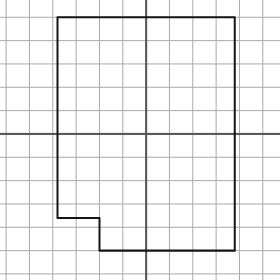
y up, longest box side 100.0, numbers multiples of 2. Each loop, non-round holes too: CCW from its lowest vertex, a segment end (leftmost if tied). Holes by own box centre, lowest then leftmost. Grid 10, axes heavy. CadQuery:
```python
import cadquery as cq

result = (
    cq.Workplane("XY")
    .moveTo(-20.0, -50.0)
    .lineTo(38.0, -50.0)
    .lineTo(38.0, 50.0)
    .lineTo(-38.0, 50.0)
    .lineTo(-38.0, -36.0)
    .lineTo(-20.0, -36.0)
    .close()
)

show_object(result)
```